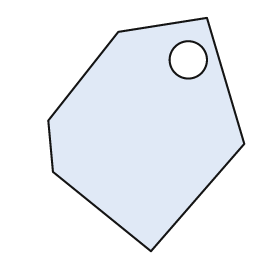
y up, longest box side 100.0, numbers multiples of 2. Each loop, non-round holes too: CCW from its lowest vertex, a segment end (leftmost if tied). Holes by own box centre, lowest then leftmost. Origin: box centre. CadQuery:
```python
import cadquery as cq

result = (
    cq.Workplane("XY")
    .moveTo(2.0, -50.0)
    .lineTo(42.0, -4.0)
    .lineTo(26.0, 50.0)
    .lineTo(-12.0, 44.0)
    .lineTo(-42.0, 6.0)
    .lineTo(-40.0, -16.0)
    .close()
    .moveTo(18.0, 32.0)
    .circle(8.0)
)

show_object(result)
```